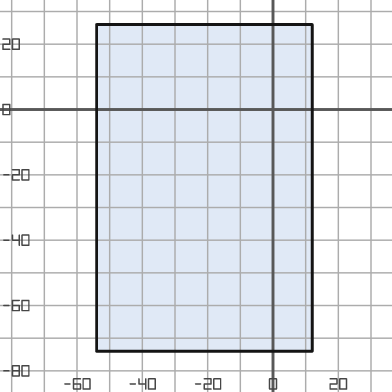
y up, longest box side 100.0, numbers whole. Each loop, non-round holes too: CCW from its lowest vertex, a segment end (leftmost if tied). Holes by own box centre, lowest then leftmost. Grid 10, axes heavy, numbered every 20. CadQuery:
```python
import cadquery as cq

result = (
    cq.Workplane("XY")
    .moveTo(-54.0, -74.0)
    .lineTo(12.0, -74.0)
    .lineTo(12.0, 26.0)
    .lineTo(-54.0, 26.0)
    .close()
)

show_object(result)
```